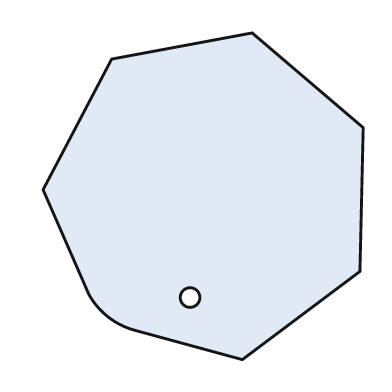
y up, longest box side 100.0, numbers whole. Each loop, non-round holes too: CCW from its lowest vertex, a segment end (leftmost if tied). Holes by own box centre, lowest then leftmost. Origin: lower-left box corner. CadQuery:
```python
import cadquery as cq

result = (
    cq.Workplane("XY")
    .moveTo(61.0, 0.0)
    .lineTo(97.0, 27.0)
    .lineTo(98.0, 71.0)
    .lineTo(64.0, 100.0)
    .lineTo(21.0, 92.0)
    .lineTo(0.0, 52.0)
    .lineTo(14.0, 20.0)
    .threePointArc((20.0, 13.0), (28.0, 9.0))
    .close()
    .moveTo(45.0, 19.0)
    .circle(3.0)
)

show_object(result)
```